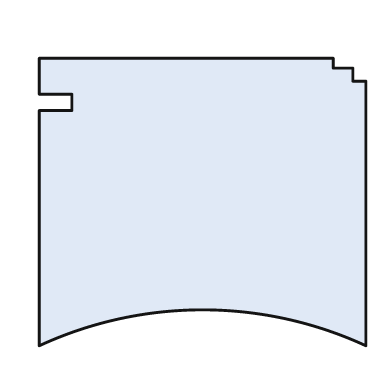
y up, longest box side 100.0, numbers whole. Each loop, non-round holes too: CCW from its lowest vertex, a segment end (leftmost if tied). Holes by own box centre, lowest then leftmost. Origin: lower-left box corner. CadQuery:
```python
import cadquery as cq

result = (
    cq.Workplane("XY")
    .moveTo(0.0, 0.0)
    .threePointArc((50.0, 11.0), (100.0, 0.0))
    .lineTo(100.0, 81.0)
    .lineTo(96.0, 81.0)
    .lineTo(96.0, 85.0)
    .lineTo(90.0, 85.0)
    .lineTo(90.0, 88.0)
    .lineTo(0.0, 88.0)
    .lineTo(0.0, 77.0)
    .lineTo(10.0, 77.0)
    .lineTo(10.0, 72.0)
    .lineTo(0.0, 72.0)
    .close()
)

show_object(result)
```